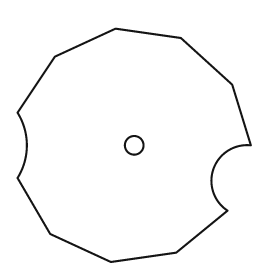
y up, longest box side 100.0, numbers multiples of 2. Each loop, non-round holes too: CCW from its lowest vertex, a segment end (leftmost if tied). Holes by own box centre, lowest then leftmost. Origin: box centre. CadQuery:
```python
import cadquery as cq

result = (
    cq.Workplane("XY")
    .moveTo(-10.0, -50.0)
    .lineTo(18.0, -46.0)
    .lineTo(40.0, -28.0)
    .threePointArc((34.0, -10.0), (50.0, 0.0))
    .lineTo(42.0, 26.0)
    .lineTo(20.0, 46.0)
    .lineTo(-8.0, 50.0)
    .lineTo(-34.0, 38.0)
    .lineTo(-50.0, 14.0)
    .threePointArc((-46.0, 0.0), (-50.0, -14.0))
    .lineTo(-36.0, -38.0)
    .close()
    .moveTo(0.0, 0.0)
    .circle(4.0)
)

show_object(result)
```